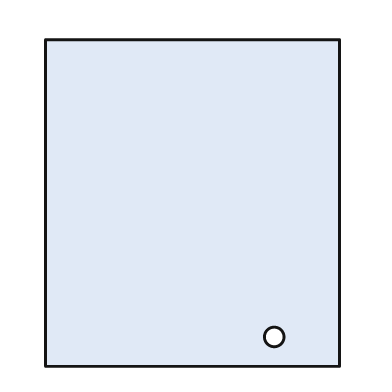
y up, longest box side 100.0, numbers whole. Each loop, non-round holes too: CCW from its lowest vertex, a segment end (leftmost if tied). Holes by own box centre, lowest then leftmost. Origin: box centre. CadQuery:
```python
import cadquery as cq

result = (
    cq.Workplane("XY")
    .moveTo(-45.0, -50.0)
    .lineTo(45.0, -50.0)
    .lineTo(45.0, 50.0)
    .lineTo(-45.0, 50.0)
    .close()
    .moveTo(25.0, -41.0)
    .circle(3.0)
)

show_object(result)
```